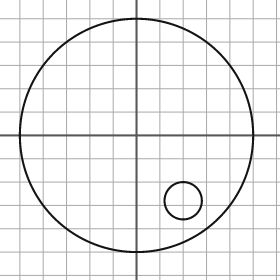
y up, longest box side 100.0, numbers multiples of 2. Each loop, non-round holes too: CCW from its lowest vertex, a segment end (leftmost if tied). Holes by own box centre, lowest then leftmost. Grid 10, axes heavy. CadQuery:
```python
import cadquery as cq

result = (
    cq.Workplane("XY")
    .moveTo(0.0, 0.0)
    .circle(50.0)
    .moveTo(20.0, -28.0)
    .circle(8.0)
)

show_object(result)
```